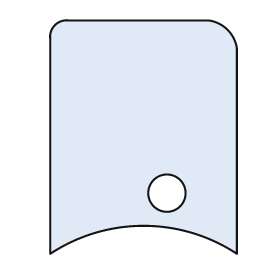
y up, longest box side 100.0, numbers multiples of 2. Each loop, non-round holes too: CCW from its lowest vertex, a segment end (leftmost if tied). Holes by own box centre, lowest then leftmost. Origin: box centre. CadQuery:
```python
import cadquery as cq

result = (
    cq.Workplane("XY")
    .moveTo(-40.0, -50.0)
    .threePointArc((0.0, -38.0), (40.0, -50.0))
    .lineTo(40.0, 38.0)
    .threePointArc((36.0, 46.0), (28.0, 50.0))
    .lineTo(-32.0, 50.0)
    .threePointArc((-38.0, 48.0), (-40.0, 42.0))
    .close()
    .moveTo(10.0, -24.0)
    .circle(8.0)
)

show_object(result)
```